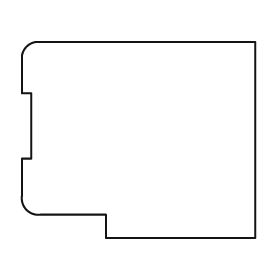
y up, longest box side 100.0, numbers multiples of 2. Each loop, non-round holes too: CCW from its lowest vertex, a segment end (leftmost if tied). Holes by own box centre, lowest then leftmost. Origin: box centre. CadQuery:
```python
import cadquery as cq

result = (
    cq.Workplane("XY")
    .moveTo(-14.0, -42.0)
    .lineTo(50.0, -42.0)
    .lineTo(50.0, 42.0)
    .lineTo(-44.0, 42.0)
    .threePointArc((-48.0, 40.0), (-50.0, 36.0))
    .lineTo(-50.0, 20.0)
    .lineTo(-46.0, 20.0)
    .lineTo(-46.0, -8.0)
    .lineTo(-50.0, -8.0)
    .lineTo(-50.0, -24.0)
    .threePointArc((-48.0, -30.0), (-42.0, -32.0))
    .lineTo(-14.0, -32.0)
    .close()
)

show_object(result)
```